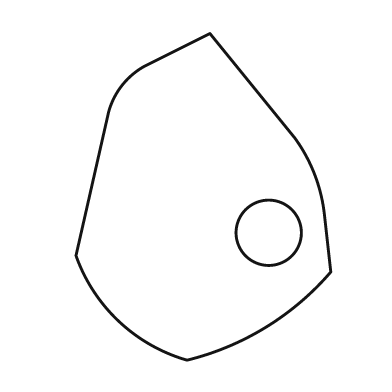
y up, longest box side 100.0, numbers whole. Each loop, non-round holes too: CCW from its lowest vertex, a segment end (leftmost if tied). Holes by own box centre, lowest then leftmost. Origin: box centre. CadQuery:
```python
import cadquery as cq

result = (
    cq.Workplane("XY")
    .moveTo(-5.0, -50.0)
    .threePointArc((19.0, -40.0), (39.0, -23.0))
    .lineTo(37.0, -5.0)
    .threePointArc((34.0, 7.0), (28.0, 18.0))
    .lineTo(2.0, 50.0)
    .lineTo(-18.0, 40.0)
    .threePointArc((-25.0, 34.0), (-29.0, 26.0))
    .lineTo(-39.0, -18.0)
    .threePointArc((-26.0, -38.0), (-5.0, -50.0))
    .close()
    .moveTo(20.0, -11.0)
    .circle(10.0)
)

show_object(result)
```